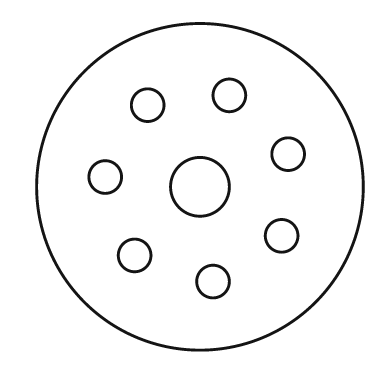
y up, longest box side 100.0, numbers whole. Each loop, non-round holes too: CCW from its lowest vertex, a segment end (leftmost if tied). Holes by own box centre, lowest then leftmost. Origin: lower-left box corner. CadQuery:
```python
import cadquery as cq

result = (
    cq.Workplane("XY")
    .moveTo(50.0, 50.0)
    .circle(50.0)
    .moveTo(54.0, 21.0)
    .circle(5.0)
    .moveTo(30.0, 29.0)
    .circle(5.0)
    .moveTo(75.0, 35.0)
    .circle(5.0)
    .moveTo(50.0, 50.0)
    .circle(9.0)
    .moveTo(21.0, 53.0)
    .circle(5.0)
    .moveTo(77.0, 60.0)
    .circle(5.0)
    .moveTo(34.0, 75.0)
    .circle(5.0)
    .moveTo(59.0, 78.0)
    .circle(5.0)
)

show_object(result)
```